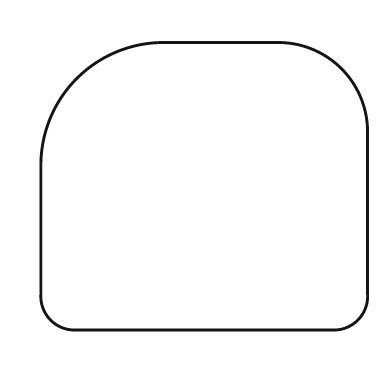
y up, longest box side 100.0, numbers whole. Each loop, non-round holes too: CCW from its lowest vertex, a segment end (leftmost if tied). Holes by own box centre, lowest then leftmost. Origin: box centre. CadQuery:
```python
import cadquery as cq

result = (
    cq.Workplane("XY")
    .moveTo(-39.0, -44.0)
    .lineTo(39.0, -44.0)
    .threePointArc((47.0, -41.0), (50.0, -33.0))
    .lineTo(50.0, 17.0)
    .threePointArc((42.0, 36.0), (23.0, 44.0))
    .lineTo(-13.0, 44.0)
    .threePointArc((-39.0, 33.0), (-50.0, 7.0))
    .lineTo(-50.0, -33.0)
    .threePointArc((-47.0, -41.0), (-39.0, -44.0))
    .close()
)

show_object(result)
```